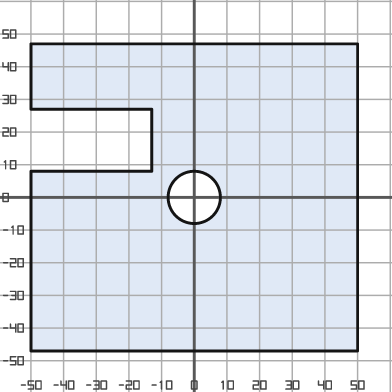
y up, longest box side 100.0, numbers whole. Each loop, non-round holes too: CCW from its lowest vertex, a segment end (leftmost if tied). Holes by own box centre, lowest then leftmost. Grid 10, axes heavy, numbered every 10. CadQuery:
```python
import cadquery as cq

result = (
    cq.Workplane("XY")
    .moveTo(-50.0, -47.0)
    .lineTo(50.0, -47.0)
    .lineTo(50.0, 47.0)
    .lineTo(-50.0, 47.0)
    .lineTo(-50.0, 27.0)
    .lineTo(-13.0, 27.0)
    .lineTo(-13.0, 8.0)
    .lineTo(-50.0, 8.0)
    .close()
    .moveTo(0.0, 0.0)
    .circle(8.0)
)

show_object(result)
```